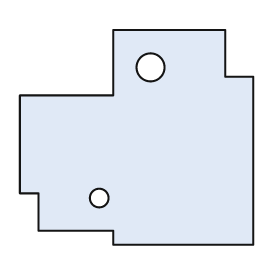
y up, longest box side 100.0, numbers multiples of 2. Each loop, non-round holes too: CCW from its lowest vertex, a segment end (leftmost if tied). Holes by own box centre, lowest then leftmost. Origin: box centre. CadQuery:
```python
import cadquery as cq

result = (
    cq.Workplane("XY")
    .moveTo(-10.0, -46.0)
    .lineTo(50.0, -46.0)
    .lineTo(50.0, 26.0)
    .lineTo(38.0, 26.0)
    .lineTo(38.0, 46.0)
    .lineTo(-10.0, 46.0)
    .lineTo(-10.0, 18.0)
    .lineTo(-50.0, 18.0)
    .lineTo(-50.0, -24.0)
    .lineTo(-42.0, -24.0)
    .lineTo(-42.0, -40.0)
    .lineTo(-10.0, -40.0)
    .close()
    .moveTo(-16.0, -26.0)
    .circle(4.0)
    .moveTo(6.0, 30.0)
    .circle(6.0)
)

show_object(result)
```